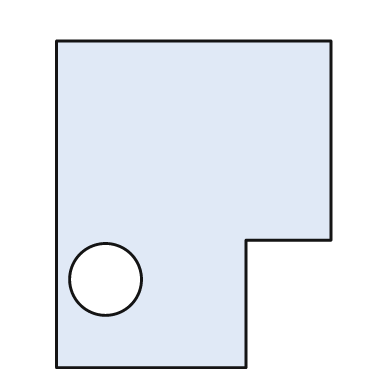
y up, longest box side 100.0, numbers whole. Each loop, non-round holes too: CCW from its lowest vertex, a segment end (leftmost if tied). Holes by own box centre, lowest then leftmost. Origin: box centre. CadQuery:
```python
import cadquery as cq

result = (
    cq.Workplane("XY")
    .moveTo(-42.0, -50.0)
    .lineTo(16.0, -50.0)
    .lineTo(16.0, -11.0)
    .lineTo(42.0, -11.0)
    .lineTo(42.0, 50.0)
    .lineTo(-42.0, 50.0)
    .close()
    .moveTo(-27.0, -23.0)
    .circle(11.0)
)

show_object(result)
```